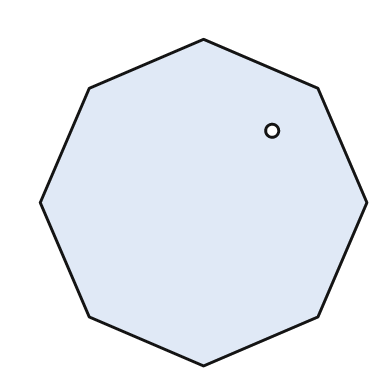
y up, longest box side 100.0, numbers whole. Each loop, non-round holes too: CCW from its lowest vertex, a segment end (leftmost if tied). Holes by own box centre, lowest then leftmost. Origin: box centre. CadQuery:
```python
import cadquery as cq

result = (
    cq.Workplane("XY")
    .moveTo(0.0, -50.0)
    .lineTo(35.0, -35.0)
    .lineTo(50.0, 0.0)
    .lineTo(35.0, 35.0)
    .lineTo(0.0, 50.0)
    .lineTo(-35.0, 35.0)
    .lineTo(-50.0, 0.0)
    .lineTo(-35.0, -35.0)
    .close()
    .moveTo(21.0, 22.0)
    .circle(2.0)
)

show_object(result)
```